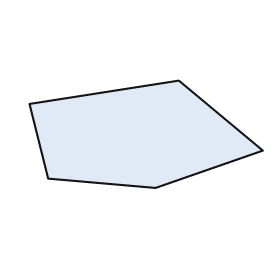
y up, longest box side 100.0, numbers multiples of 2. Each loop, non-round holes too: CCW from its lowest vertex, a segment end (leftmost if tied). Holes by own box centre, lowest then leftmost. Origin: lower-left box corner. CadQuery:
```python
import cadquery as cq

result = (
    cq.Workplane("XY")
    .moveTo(54.0, 0.0)
    .lineTo(100.0, 16.0)
    .lineTo(64.0, 46.0)
    .lineTo(0.0, 36.0)
    .lineTo(8.0, 4.0)
    .close()
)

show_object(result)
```